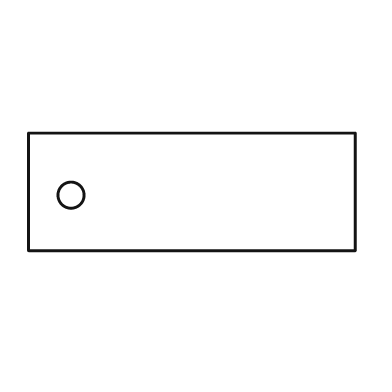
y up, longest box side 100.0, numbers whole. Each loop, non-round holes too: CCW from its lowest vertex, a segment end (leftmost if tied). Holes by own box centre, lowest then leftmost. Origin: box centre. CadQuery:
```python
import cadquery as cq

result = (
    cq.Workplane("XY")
    .moveTo(-50.0, -18.0)
    .lineTo(50.0, -18.0)
    .lineTo(50.0, 18.0)
    .lineTo(-50.0, 18.0)
    .close()
    .moveTo(-37.0, -1.0)
    .circle(4.0)
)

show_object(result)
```